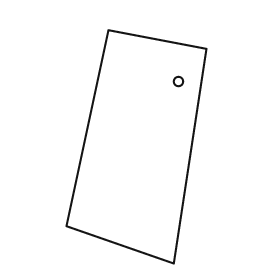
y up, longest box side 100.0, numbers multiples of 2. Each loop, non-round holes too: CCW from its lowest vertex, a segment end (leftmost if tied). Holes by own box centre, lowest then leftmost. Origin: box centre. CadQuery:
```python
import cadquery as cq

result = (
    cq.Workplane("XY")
    .moveTo(16.0, -50.0)
    .lineTo(30.0, 42.0)
    .lineTo(-12.0, 50.0)
    .lineTo(-30.0, -34.0)
    .close()
    .moveTo(18.0, 28.0)
    .circle(2.0)
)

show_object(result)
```